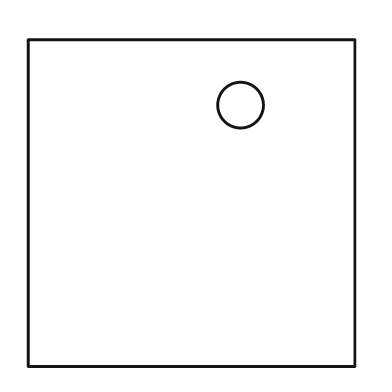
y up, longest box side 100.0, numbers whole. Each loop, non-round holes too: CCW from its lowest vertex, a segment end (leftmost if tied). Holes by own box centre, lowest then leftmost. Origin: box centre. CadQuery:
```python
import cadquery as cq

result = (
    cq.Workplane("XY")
    .moveTo(-50.0, -50.0)
    .lineTo(50.0, -50.0)
    .lineTo(50.0, 50.0)
    .lineTo(-50.0, 50.0)
    .close()
    .moveTo(15.0, 30.0)
    .circle(7.0)
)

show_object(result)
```